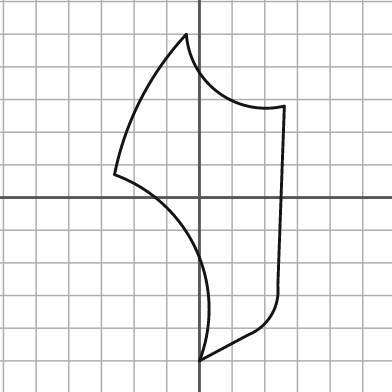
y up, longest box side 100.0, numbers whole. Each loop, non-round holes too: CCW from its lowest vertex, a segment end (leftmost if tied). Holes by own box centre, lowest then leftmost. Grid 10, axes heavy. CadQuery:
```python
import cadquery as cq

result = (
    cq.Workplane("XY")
    .moveTo(0.0, -50.0)
    .lineTo(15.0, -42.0)
    .threePointArc((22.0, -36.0), (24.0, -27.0))
    .lineTo(26.0, 28.0)
    .threePointArc((6.0, 32.0), (-4.0, 50.0))
    .threePointArc((-18.0, 30.0), (-26.0, 7.0))
    .threePointArc((-1.0, -16.0), (0.0, -50.0))
    .close()
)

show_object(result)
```